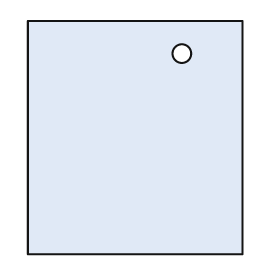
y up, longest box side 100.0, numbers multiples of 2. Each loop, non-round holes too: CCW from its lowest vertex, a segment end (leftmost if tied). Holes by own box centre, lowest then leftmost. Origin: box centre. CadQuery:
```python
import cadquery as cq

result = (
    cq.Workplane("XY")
    .moveTo(-46.0, -50.0)
    .lineTo(46.0, -50.0)
    .lineTo(46.0, 50.0)
    .lineTo(-46.0, 50.0)
    .close()
    .moveTo(20.0, 36.0)
    .circle(4.0)
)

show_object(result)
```